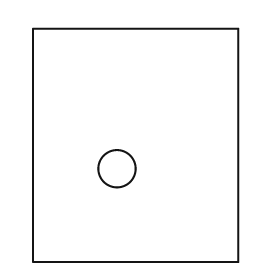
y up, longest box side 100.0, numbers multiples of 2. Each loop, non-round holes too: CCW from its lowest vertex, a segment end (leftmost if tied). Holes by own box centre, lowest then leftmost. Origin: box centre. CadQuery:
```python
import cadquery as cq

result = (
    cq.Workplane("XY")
    .moveTo(-44.0, -50.0)
    .lineTo(44.0, -50.0)
    .lineTo(44.0, 50.0)
    .lineTo(-44.0, 50.0)
    .close()
    .moveTo(-8.0, -10.0)
    .circle(8.0)
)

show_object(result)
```